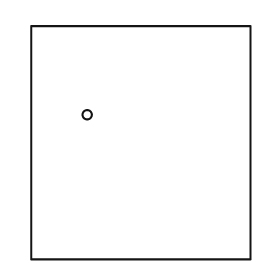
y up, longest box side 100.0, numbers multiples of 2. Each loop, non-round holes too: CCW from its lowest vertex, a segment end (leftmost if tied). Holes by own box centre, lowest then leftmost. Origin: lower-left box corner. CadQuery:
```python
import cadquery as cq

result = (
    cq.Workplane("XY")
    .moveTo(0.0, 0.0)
    .lineTo(94.0, 0.0)
    .lineTo(94.0, 100.0)
    .lineTo(0.0, 100.0)
    .close()
    .moveTo(24.0, 62.0)
    .circle(2.0)
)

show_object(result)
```